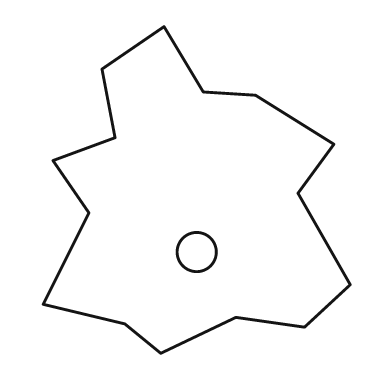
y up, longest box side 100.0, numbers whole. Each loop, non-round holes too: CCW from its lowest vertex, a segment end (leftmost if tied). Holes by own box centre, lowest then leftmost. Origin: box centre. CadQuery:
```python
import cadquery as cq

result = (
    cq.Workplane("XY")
    .moveTo(-11.0, -50.0)
    .lineTo(12.0, -39.0)
    .lineTo(33.0, -42.0)
    .lineTo(47.0, -29.0)
    .lineTo(31.0, -1.0)
    .lineTo(42.0, 14.0)
    .lineTo(18.0, 29.0)
    .lineTo(2.0, 30.0)
    .lineTo(-10.0, 50.0)
    .lineTo(-29.0, 37.0)
    .lineTo(-25.0, 16.0)
    .lineTo(-44.0, 9.0)
    .lineTo(-33.0, -7.0)
    .lineTo(-47.0, -35.0)
    .lineTo(-22.0, -41.0)
    .close()
    .moveTo(0.0, -19.0)
    .circle(6.0)
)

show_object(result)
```